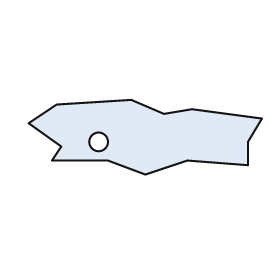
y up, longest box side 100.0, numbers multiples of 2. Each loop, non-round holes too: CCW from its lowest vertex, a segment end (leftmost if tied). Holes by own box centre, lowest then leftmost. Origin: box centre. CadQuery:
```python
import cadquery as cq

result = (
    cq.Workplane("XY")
    .moveTo(0.0, -16.0)
    .lineTo(18.0, -10.0)
    .lineTo(44.0, -12.0)
    .lineTo(44.0, -2.0)
    .lineTo(50.0, 8.0)
    .lineTo(20.0, 12.0)
    .lineTo(8.0, 10.0)
    .lineTo(-6.0, 16.0)
    .lineTo(-38.0, 14.0)
    .lineTo(-50.0, 6.0)
    .lineTo(-36.0, -4.0)
    .lineTo(-40.0, -10.0)
    .lineTo(-16.0, -10.0)
    .close()
    .moveTo(-20.0, -2.0)
    .circle(4.0)
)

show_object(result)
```